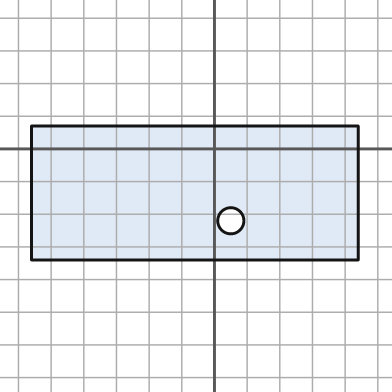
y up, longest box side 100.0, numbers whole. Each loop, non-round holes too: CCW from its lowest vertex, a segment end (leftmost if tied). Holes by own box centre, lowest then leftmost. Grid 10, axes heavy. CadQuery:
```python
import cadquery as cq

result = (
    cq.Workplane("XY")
    .moveTo(-56.0, -34.0)
    .lineTo(44.0, -34.0)
    .lineTo(44.0, 7.0)
    .lineTo(-56.0, 7.0)
    .close()
    .moveTo(5.0, -22.0)
    .circle(4.0)
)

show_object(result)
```